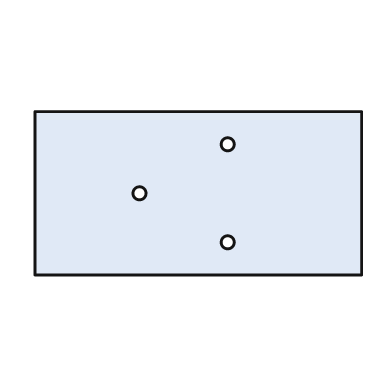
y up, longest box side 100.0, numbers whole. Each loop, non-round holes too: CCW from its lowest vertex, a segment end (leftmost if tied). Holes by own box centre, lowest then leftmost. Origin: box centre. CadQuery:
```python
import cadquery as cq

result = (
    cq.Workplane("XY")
    .moveTo(-50.0, -25.0)
    .lineTo(50.0, -25.0)
    .lineTo(50.0, 25.0)
    .lineTo(-50.0, 25.0)
    .close()
    .moveTo(9.0, -15.0)
    .circle(2.0)
    .moveTo(-18.0, 0.0)
    .circle(2.0)
    .moveTo(9.0, 15.0)
    .circle(2.0)
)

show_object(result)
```